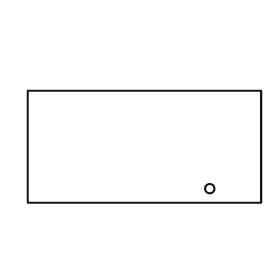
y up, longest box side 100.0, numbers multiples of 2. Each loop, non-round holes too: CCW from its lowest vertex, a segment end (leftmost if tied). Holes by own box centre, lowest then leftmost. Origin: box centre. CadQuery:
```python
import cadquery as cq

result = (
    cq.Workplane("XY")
    .moveTo(-50.0, -24.0)
    .lineTo(50.0, -24.0)
    .lineTo(50.0, 24.0)
    .lineTo(-50.0, 24.0)
    .close()
    .moveTo(28.0, -18.0)
    .circle(2.0)
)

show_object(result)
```